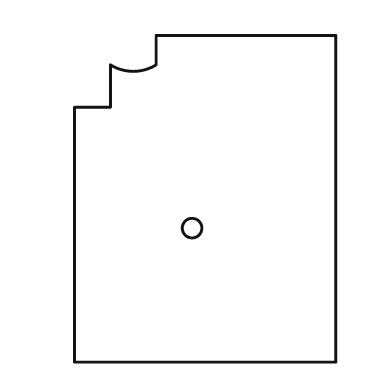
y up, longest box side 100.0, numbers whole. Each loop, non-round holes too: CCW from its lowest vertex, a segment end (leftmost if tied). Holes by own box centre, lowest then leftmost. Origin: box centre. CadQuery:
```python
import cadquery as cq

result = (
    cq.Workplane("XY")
    .moveTo(-40.0, -50.0)
    .lineTo(40.0, -50.0)
    .lineTo(40.0, 50.0)
    .lineTo(-15.0, 50.0)
    .lineTo(-15.0, 41.0)
    .threePointArc((-22.0, 39.0), (-29.0, 41.0))
    .lineTo(-29.0, 28.0)
    .lineTo(-40.0, 28.0)
    .close()
    .moveTo(-4.0, -9.0)
    .circle(3.0)
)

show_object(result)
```